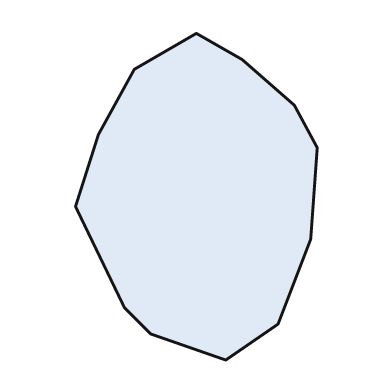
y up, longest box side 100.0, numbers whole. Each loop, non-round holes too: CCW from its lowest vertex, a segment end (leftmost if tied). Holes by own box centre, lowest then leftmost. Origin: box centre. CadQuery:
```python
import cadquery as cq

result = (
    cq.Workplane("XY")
    .moveTo(9.0, -50.0)
    .lineTo(25.0, -39.0)
    .lineTo(35.0, -13.0)
    .lineTo(37.0, 15.0)
    .lineTo(30.0, 28.0)
    .lineTo(14.0, 42.0)
    .lineTo(0.0, 50.0)
    .lineTo(-19.0, 39.0)
    .lineTo(-30.0, 19.0)
    .lineTo(-37.0, -3.0)
    .lineTo(-22.0, -34.0)
    .lineTo(-14.0, -42.0)
    .close()
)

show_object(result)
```